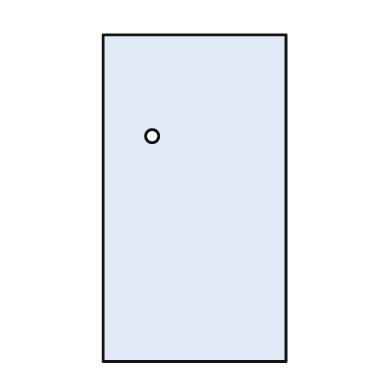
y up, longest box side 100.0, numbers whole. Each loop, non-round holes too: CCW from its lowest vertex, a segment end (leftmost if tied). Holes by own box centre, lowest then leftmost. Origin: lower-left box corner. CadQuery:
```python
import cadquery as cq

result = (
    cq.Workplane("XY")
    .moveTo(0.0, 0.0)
    .lineTo(56.0, 0.0)
    .lineTo(56.0, 100.0)
    .lineTo(0.0, 100.0)
    .close()
    .moveTo(15.0, 69.0)
    .circle(2.0)
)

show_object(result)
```